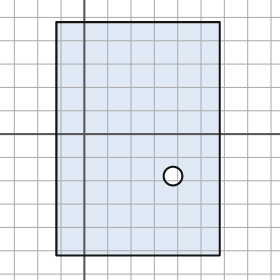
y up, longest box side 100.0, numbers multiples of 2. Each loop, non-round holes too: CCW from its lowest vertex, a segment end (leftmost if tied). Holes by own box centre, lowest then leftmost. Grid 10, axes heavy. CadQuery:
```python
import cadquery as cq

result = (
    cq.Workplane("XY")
    .moveTo(-12.0, -52.0)
    .lineTo(58.0, -52.0)
    .lineTo(58.0, 48.0)
    .lineTo(-12.0, 48.0)
    .close()
    .moveTo(38.0, -18.0)
    .circle(4.0)
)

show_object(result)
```